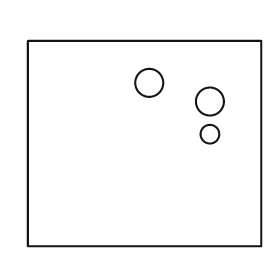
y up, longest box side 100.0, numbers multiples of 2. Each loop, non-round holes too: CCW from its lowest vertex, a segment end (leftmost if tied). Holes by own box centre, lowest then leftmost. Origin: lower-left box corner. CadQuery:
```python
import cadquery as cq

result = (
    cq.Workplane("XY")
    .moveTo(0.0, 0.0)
    .lineTo(100.0, 0.0)
    .lineTo(100.0, 88.0)
    .lineTo(0.0, 88.0)
    .close()
    .moveTo(78.0, 48.0)
    .circle(4.0)
    .moveTo(78.0, 62.0)
    .circle(6.0)
    .moveTo(52.0, 70.0)
    .circle(6.0)
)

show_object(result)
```